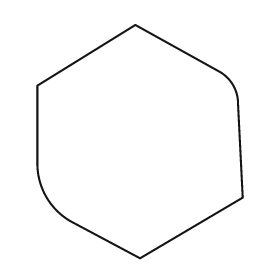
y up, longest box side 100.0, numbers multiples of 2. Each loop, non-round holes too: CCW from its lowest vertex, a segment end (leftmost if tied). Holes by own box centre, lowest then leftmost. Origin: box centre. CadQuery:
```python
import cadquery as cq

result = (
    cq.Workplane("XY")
    .moveTo(0.0, -50.0)
    .lineTo(44.0, -24.0)
    .lineTo(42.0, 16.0)
    .threePointArc((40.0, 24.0), (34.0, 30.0))
    .lineTo(-2.0, 50.0)
    .lineTo(-44.0, 24.0)
    .lineTo(-44.0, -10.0)
    .threePointArc((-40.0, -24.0), (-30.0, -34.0))
    .close()
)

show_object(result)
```